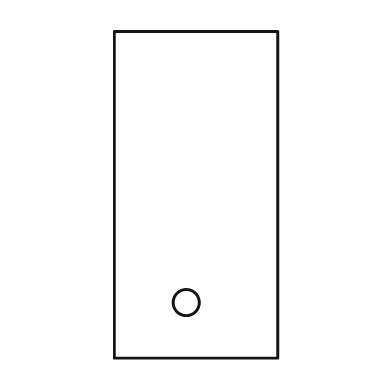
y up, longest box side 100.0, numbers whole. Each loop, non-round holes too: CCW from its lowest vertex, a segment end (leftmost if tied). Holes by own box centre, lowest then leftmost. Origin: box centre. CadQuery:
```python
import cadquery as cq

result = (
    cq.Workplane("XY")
    .moveTo(-25.0, -50.0)
    .lineTo(25.0, -50.0)
    .lineTo(25.0, 50.0)
    .lineTo(-25.0, 50.0)
    .close()
    .moveTo(-3.0, -33.0)
    .circle(4.0)
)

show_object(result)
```